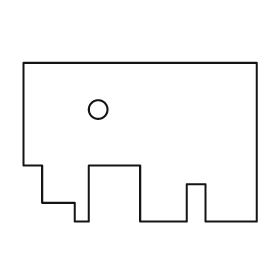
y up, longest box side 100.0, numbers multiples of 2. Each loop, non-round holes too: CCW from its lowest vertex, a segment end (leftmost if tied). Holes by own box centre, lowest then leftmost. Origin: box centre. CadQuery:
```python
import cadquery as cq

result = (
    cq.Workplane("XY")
    .moveTo(-28.0, -34.0)
    .lineTo(-22.0, -34.0)
    .lineTo(-22.0, -10.0)
    .lineTo(0.0, -10.0)
    .lineTo(0.0, -34.0)
    .lineTo(20.0, -34.0)
    .lineTo(20.0, -18.0)
    .lineTo(28.0, -18.0)
    .lineTo(28.0, -34.0)
    .lineTo(50.0, -34.0)
    .lineTo(50.0, 34.0)
    .lineTo(-50.0, 34.0)
    .lineTo(-50.0, -10.0)
    .lineTo(-42.0, -10.0)
    .lineTo(-42.0, -26.0)
    .lineTo(-28.0, -26.0)
    .close()
    .moveTo(-18.0, 14.0)
    .circle(4.0)
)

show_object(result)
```